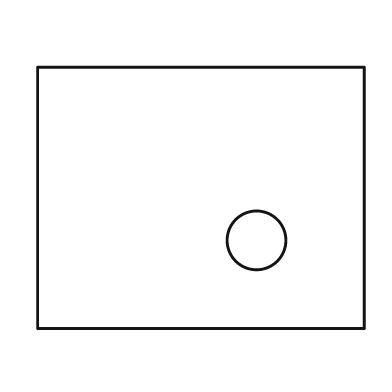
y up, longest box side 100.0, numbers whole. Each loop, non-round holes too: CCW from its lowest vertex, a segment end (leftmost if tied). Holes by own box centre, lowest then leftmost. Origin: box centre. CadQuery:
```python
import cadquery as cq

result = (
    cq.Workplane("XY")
    .moveTo(-50.0, -40.0)
    .lineTo(50.0, -40.0)
    .lineTo(50.0, 40.0)
    .lineTo(-50.0, 40.0)
    .close()
    .moveTo(17.0, -13.0)
    .circle(9.0)
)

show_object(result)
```